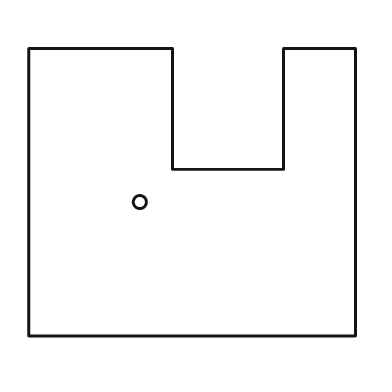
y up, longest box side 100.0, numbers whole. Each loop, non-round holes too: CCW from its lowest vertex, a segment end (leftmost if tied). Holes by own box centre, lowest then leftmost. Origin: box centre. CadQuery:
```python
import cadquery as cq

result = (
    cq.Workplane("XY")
    .moveTo(-50.0, -44.0)
    .lineTo(50.0, -44.0)
    .lineTo(50.0, 44.0)
    .lineTo(28.0, 44.0)
    .lineTo(28.0, 7.0)
    .lineTo(-6.0, 7.0)
    .lineTo(-6.0, 44.0)
    .lineTo(-50.0, 44.0)
    .close()
    .moveTo(-16.0, -3.0)
    .circle(2.0)
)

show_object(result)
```